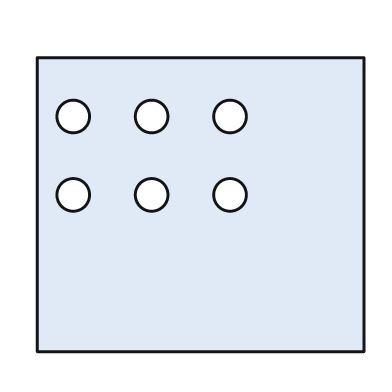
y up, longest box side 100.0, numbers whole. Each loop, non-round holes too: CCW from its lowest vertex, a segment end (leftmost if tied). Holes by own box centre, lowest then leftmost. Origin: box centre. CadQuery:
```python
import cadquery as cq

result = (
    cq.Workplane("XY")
    .moveTo(-50.0, -45.0)
    .lineTo(50.0, -45.0)
    .lineTo(50.0, 45.0)
    .lineTo(-50.0, 45.0)
    .close()
    .moveTo(-39.0, 3.0)
    .circle(5.0)
    .moveTo(-15.0, 3.0)
    .circle(5.0)
    .moveTo(9.0, 3.0)
    .circle(5.0)
    .moveTo(-39.0, 27.0)
    .circle(5.0)
    .moveTo(-15.0, 27.0)
    .circle(5.0)
    .moveTo(9.0, 27.0)
    .circle(5.0)
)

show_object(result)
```